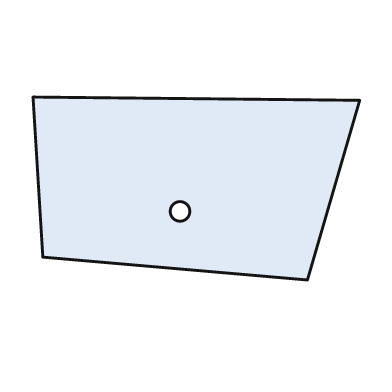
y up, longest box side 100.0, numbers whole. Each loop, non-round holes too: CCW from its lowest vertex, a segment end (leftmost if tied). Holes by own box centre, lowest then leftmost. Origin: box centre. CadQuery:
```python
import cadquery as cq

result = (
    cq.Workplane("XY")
    .moveTo(34.0, -28.0)
    .lineTo(50.0, 27.0)
    .lineTo(-50.0, 28.0)
    .lineTo(-47.0, -21.0)
    .close()
    .moveTo(-5.0, -7.0)
    .circle(3.0)
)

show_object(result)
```